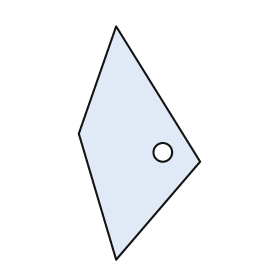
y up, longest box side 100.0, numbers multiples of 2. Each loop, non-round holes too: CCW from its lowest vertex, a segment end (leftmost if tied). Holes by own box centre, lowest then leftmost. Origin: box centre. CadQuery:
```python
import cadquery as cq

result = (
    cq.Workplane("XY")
    .moveTo(-10.0, -50.0)
    .lineTo(26.0, -8.0)
    .lineTo(-10.0, 50.0)
    .lineTo(-26.0, 4.0)
    .close()
    .moveTo(10.0, -4.0)
    .circle(4.0)
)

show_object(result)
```